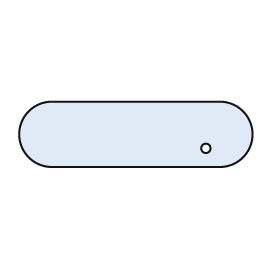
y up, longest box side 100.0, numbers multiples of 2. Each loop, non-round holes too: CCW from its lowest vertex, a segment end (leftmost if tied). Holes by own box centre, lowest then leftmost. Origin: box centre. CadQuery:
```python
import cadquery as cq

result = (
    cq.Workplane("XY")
    .moveTo(-36.0, -14.0)
    .lineTo(36.0, -14.0)
    .threePointArc((50.0, 0.0), (36.0, 14.0))
    .lineTo(-36.0, 14.0)
    .threePointArc((-50.0, 0.0), (-36.0, -14.0))
    .close()
    .moveTo(30.0, -6.0)
    .circle(2.0)
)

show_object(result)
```